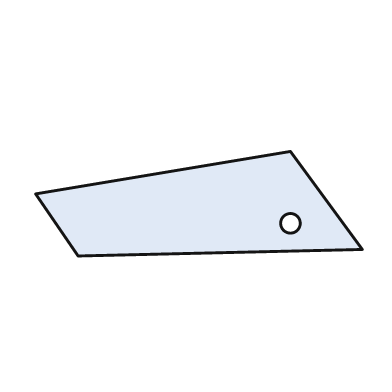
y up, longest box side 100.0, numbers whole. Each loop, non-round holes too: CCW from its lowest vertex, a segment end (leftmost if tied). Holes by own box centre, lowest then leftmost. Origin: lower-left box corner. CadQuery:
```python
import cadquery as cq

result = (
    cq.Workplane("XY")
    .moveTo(13.0, 0.0)
    .lineTo(100.0, 2.0)
    .lineTo(78.0, 32.0)
    .lineTo(0.0, 19.0)
    .close()
    .moveTo(78.0, 10.0)
    .circle(3.0)
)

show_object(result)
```